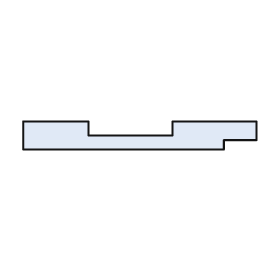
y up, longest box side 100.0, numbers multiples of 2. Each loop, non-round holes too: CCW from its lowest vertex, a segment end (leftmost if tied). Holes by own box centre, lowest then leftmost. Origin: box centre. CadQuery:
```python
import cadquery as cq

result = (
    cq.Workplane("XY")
    .moveTo(-50.0, -6.0)
    .lineTo(36.0, -6.0)
    .lineTo(36.0, -2.0)
    .lineTo(50.0, -2.0)
    .lineTo(50.0, 6.0)
    .lineTo(14.0, 6.0)
    .lineTo(14.0, 0.0)
    .lineTo(-22.0, 0.0)
    .lineTo(-22.0, 6.0)
    .lineTo(-50.0, 6.0)
    .close()
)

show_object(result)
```